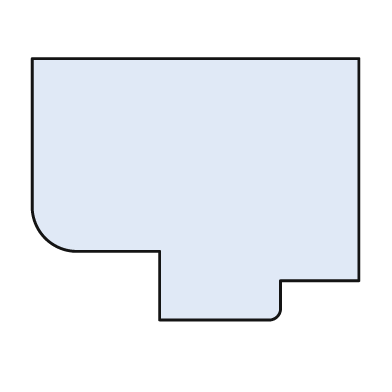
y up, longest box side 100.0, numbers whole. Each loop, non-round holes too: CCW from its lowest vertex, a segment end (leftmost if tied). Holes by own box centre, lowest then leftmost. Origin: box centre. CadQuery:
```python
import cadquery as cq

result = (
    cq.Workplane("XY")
    .moveTo(-11.0, -40.0)
    .lineTo(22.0, -40.0)
    .threePointArc((25.0, -39.0), (26.0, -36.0))
    .lineTo(26.0, -28.0)
    .lineTo(50.0, -28.0)
    .lineTo(50.0, 40.0)
    .lineTo(-50.0, 40.0)
    .lineTo(-50.0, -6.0)
    .threePointArc((-46.0, -15.0), (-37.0, -19.0))
    .lineTo(-11.0, -19.0)
    .close()
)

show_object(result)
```